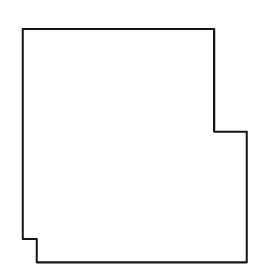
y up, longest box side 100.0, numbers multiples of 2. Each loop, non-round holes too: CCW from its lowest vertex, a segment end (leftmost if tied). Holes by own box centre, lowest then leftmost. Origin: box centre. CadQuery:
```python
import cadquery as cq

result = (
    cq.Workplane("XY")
    .moveTo(-42.0, -50.0)
    .lineTo(48.0, -50.0)
    .lineTo(48.0, 6.0)
    .lineTo(34.0, 6.0)
    .lineTo(34.0, 50.0)
    .lineTo(-48.0, 50.0)
    .lineTo(-48.0, -40.0)
    .lineTo(-42.0, -40.0)
    .close()
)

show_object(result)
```